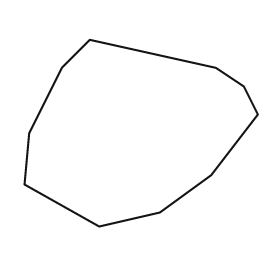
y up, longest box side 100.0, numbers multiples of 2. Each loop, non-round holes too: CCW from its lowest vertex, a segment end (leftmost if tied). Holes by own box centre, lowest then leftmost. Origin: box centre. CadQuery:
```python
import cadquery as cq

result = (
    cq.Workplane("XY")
    .moveTo(-18.0, -40.0)
    .lineTo(8.0, -34.0)
    .lineTo(30.0, -18.0)
    .lineTo(50.0, 8.0)
    .lineTo(44.0, 20.0)
    .lineTo(32.0, 28.0)
    .lineTo(-22.0, 40.0)
    .lineTo(-34.0, 28.0)
    .lineTo(-48.0, 0.0)
    .lineTo(-50.0, -22.0)
    .close()
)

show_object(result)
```